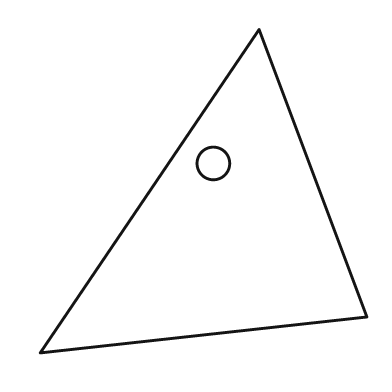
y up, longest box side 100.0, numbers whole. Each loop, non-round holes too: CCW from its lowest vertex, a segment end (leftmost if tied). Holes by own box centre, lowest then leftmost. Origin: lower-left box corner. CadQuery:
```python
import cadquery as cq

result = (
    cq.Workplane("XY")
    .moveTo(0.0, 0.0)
    .lineTo(100.0, 11.0)
    .lineTo(67.0, 99.0)
    .close()
    .moveTo(53.0, 58.0)
    .circle(5.0)
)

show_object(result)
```